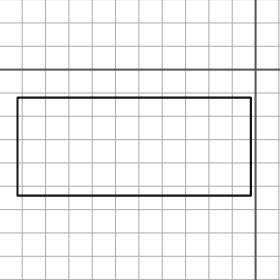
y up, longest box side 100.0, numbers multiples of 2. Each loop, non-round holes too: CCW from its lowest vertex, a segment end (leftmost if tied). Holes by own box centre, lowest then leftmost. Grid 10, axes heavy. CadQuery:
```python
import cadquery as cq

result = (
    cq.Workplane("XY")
    .moveTo(-102.0, -54.0)
    .lineTo(-2.0, -54.0)
    .lineTo(-2.0, -12.0)
    .lineTo(-102.0, -12.0)
    .close()
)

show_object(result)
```